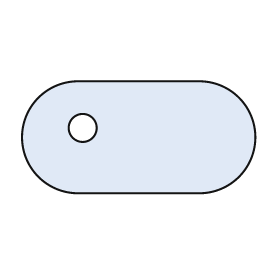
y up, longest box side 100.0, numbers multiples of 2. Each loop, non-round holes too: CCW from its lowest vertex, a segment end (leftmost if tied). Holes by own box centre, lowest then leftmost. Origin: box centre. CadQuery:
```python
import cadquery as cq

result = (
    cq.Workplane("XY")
    .moveTo(-26.0, -24.0)
    .lineTo(26.0, -24.0)
    .threePointArc((50.0, 0.0), (26.0, 24.0))
    .lineTo(-26.0, 24.0)
    .threePointArc((-50.0, 0.0), (-26.0, -24.0))
    .close()
    .moveTo(-24.0, 4.0)
    .circle(6.0)
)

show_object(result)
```